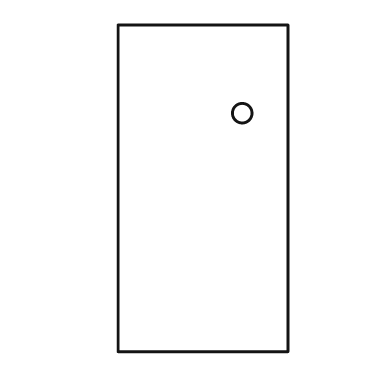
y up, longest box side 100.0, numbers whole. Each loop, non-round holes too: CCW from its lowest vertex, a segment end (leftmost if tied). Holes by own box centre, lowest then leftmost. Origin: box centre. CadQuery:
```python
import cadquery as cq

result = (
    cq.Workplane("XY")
    .moveTo(-26.0, -50.0)
    .lineTo(26.0, -50.0)
    .lineTo(26.0, 50.0)
    .lineTo(-26.0, 50.0)
    .close()
    .moveTo(12.0, 23.0)
    .circle(3.0)
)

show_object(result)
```